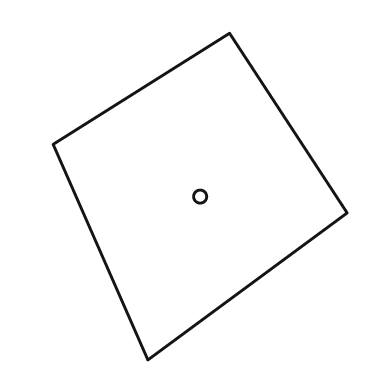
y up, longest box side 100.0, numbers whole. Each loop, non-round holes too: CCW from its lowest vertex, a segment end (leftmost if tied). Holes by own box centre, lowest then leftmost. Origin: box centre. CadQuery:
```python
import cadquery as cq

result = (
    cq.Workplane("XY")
    .moveTo(-16.0, -50.0)
    .lineTo(45.0, -5.0)
    .lineTo(9.0, 50.0)
    .lineTo(-45.0, 16.0)
    .close()
    .moveTo(0.0, 0.0)
    .circle(2.0)
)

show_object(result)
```